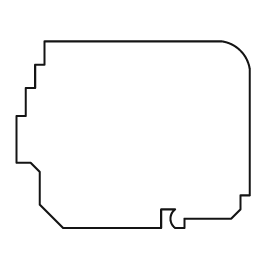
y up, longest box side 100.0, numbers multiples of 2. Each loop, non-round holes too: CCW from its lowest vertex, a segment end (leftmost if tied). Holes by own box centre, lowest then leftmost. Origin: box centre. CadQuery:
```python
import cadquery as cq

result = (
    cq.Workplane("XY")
    .moveTo(-30.0, -40.0)
    .lineTo(12.0, -40.0)
    .lineTo(12.0, -32.0)
    .lineTo(18.0, -32.0)
    .threePointArc((16.0, -36.0), (18.0, -40.0))
    .lineTo(22.0, -40.0)
    .lineTo(22.0, -36.0)
    .lineTo(42.0, -36.0)
    .lineTo(46.0, -32.0)
    .lineTo(46.0, -26.0)
    .lineTo(50.0, -26.0)
    .lineTo(50.0, 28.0)
    .threePointArc((46.0, 36.0), (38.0, 40.0))
    .lineTo(-38.0, 40.0)
    .lineTo(-38.0, 30.0)
    .lineTo(-42.0, 30.0)
    .lineTo(-42.0, 20.0)
    .lineTo(-46.0, 20.0)
    .lineTo(-46.0, 8.0)
    .lineTo(-50.0, 8.0)
    .lineTo(-50.0, -12.0)
    .lineTo(-44.0, -12.0)
    .lineTo(-40.0, -16.0)
    .lineTo(-40.0, -30.0)
    .close()
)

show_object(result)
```